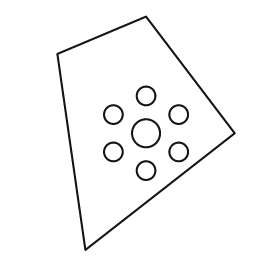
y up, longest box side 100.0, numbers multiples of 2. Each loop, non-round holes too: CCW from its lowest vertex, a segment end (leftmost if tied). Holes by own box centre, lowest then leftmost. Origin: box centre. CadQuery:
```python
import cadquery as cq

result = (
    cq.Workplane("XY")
    .moveTo(-26.0, -50.0)
    .lineTo(38.0, 0.0)
    .lineTo(0.0, 50.0)
    .lineTo(-38.0, 34.0)
    .close()
    .moveTo(0.0, -16.0)
    .circle(4.0)
    .moveTo(-14.0, -8.0)
    .circle(4.0)
    .moveTo(14.0, -8.0)
    .circle(4.0)
    .moveTo(0.0, 0.0)
    .circle(6.0)
    .moveTo(-14.0, 8.0)
    .circle(4.0)
    .moveTo(14.0, 8.0)
    .circle(4.0)
    .moveTo(0.0, 16.0)
    .circle(4.0)
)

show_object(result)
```